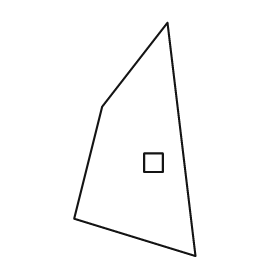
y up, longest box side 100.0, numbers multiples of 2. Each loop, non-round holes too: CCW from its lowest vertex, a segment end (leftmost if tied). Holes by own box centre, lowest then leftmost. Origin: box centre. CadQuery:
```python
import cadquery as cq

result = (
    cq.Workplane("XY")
    .moveTo(26.0, -50.0)
    .lineTo(14.0, 50.0)
    .lineTo(-14.0, 14.0)
    .lineTo(-26.0, -34.0)
    .close()
    .moveTo(4.0, -14.0)
    .lineTo(12.0, -14.0)
    .lineTo(12.0, -6.0)
    .lineTo(4.0, -6.0)
    .close()
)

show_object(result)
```